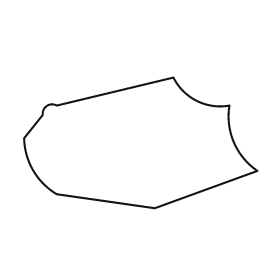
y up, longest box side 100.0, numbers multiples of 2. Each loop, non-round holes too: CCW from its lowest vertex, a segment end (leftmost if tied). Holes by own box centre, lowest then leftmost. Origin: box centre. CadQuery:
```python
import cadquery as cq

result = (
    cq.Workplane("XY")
    .moveTo(6.0, -28.0)
    .lineTo(50.0, -12.0)
    .threePointArc((40.0, 0.0), (38.0, 16.0))
    .threePointArc((24.0, 18.0), (14.0, 28.0))
    .lineTo(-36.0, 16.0)
    .threePointArc((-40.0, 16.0), (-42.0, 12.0))
    .lineTo(-50.0, 2.0)
    .threePointArc((-46.0, -12.0), (-36.0, -22.0))
    .close()
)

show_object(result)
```